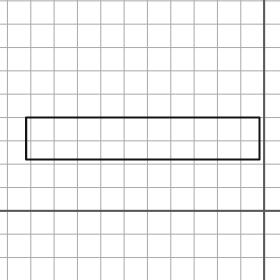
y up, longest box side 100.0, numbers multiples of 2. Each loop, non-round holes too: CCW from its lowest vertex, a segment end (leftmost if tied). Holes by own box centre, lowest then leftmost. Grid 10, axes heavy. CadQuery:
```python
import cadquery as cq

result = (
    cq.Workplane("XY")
    .moveTo(-102.0, 22.0)
    .lineTo(-2.0, 22.0)
    .lineTo(-2.0, 40.0)
    .lineTo(-102.0, 40.0)
    .close()
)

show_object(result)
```